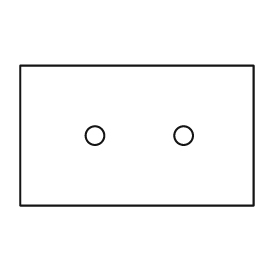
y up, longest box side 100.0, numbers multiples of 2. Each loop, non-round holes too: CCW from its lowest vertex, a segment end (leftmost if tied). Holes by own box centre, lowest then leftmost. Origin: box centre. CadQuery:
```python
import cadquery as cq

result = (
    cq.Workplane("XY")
    .moveTo(-50.0, -30.0)
    .lineTo(50.0, -30.0)
    .lineTo(50.0, 30.0)
    .lineTo(-50.0, 30.0)
    .close()
    .moveTo(-18.0, 0.0)
    .circle(4.0)
    .moveTo(20.0, 0.0)
    .circle(4.0)
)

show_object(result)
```